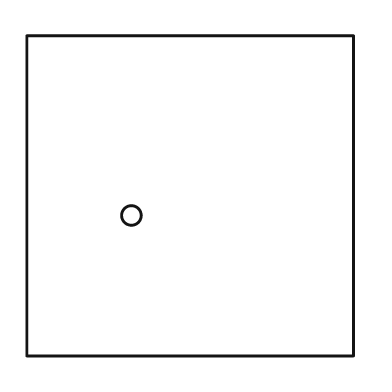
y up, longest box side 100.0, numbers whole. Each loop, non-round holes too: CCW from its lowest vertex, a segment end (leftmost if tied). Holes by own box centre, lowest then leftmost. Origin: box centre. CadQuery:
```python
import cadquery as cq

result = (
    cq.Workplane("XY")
    .moveTo(-50.0, -49.0)
    .lineTo(50.0, -49.0)
    .lineTo(50.0, 49.0)
    .lineTo(-50.0, 49.0)
    .close()
    .moveTo(-18.0, -6.0)
    .circle(3.0)
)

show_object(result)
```